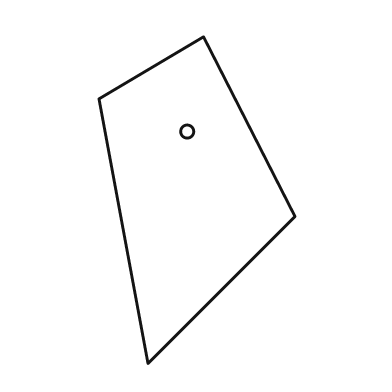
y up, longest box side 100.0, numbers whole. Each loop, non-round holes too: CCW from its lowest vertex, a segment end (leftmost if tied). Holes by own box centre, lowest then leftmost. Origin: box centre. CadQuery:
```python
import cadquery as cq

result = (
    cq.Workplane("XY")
    .moveTo(-15.0, -50.0)
    .lineTo(30.0, -5.0)
    .lineTo(2.0, 50.0)
    .lineTo(-30.0, 31.0)
    .close()
    .moveTo(-3.0, 21.0)
    .circle(2.0)
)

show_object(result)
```